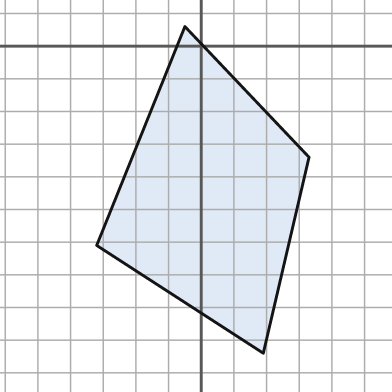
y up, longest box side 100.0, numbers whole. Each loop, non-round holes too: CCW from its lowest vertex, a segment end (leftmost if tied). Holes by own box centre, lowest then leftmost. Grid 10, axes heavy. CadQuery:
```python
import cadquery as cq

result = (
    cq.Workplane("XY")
    .moveTo(19.0, -94.0)
    .lineTo(33.0, -34.0)
    .lineTo(-5.0, 6.0)
    .lineTo(-32.0, -61.0)
    .close()
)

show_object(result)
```